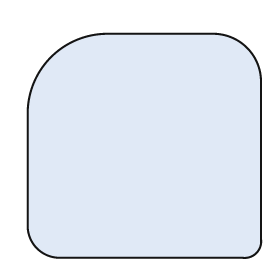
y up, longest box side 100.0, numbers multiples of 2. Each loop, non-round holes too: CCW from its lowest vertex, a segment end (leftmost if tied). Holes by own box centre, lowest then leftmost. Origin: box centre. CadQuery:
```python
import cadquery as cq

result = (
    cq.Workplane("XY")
    .moveTo(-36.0, -48.0)
    .lineTo(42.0, -48.0)
    .threePointArc((48.0, -46.0), (50.0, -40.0))
    .lineTo(50.0, 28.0)
    .threePointArc((44.0, 42.0), (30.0, 48.0))
    .lineTo(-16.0, 48.0)
    .threePointArc((-40.0, 38.0), (-50.0, 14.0))
    .lineTo(-50.0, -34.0)
    .threePointArc((-46.0, -44.0), (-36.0, -48.0))
    .close()
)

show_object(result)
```